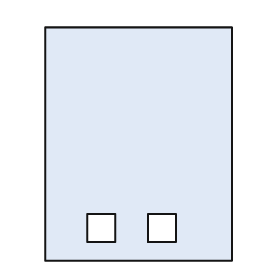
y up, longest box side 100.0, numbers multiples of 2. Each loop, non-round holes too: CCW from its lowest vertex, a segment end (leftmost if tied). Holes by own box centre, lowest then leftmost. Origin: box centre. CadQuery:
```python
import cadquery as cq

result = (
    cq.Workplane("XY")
    .moveTo(-40.0, -50.0)
    .lineTo(40.0, -50.0)
    .lineTo(40.0, 50.0)
    .lineTo(-40.0, 50.0)
    .close()
    .moveTo(-22.0, -42.0)
    .lineTo(-10.0, -42.0)
    .lineTo(-10.0, -30.0)
    .lineTo(-22.0, -30.0)
    .close()
    .moveTo(4.0, -42.0)
    .lineTo(16.0, -42.0)
    .lineTo(16.0, -30.0)
    .lineTo(4.0, -30.0)
    .close()
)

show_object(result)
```